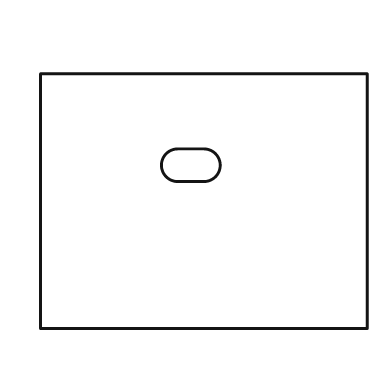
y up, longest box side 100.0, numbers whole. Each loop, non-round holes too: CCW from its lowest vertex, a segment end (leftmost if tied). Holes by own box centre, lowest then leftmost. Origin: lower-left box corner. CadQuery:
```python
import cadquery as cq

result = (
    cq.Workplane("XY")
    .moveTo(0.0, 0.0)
    .lineTo(100.0, 0.0)
    .lineTo(100.0, 78.0)
    .lineTo(0.0, 78.0)
    .close()
    .moveTo(42.0, 45.0)
    .lineTo(50.0, 45.0)
    .threePointArc((55.0, 50.0), (50.0, 55.0))
    .lineTo(42.0, 55.0)
    .threePointArc((37.0, 50.0), (42.0, 45.0))
    .close()
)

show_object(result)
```